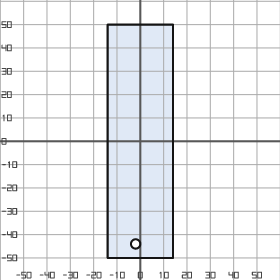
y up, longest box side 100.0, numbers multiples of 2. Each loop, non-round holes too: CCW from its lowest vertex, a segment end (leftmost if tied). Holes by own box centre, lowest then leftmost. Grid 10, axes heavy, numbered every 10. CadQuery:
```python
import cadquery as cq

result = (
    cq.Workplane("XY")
    .moveTo(-14.0, -50.0)
    .lineTo(14.0, -50.0)
    .lineTo(14.0, 50.0)
    .lineTo(-14.0, 50.0)
    .close()
    .moveTo(-2.0, -44.0)
    .circle(2.0)
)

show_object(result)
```